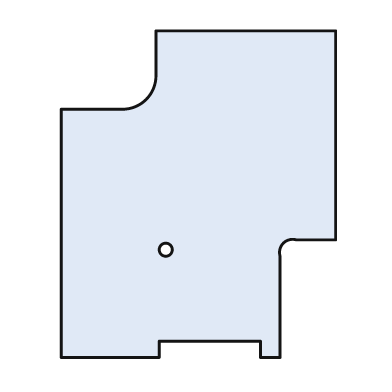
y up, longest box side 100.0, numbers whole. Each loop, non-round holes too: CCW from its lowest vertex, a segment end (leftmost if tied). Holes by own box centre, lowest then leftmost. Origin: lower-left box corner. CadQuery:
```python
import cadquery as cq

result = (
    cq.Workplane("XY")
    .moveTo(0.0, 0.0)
    .lineTo(30.0, 0.0)
    .lineTo(30.0, 5.0)
    .lineTo(61.0, 5.0)
    .lineTo(61.0, 0.0)
    .lineTo(67.0, 0.0)
    .lineTo(67.0, 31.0)
    .threePointArc((68.0, 35.0), (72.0, 36.0))
    .lineTo(84.0, 36.0)
    .lineTo(84.0, 100.0)
    .lineTo(29.0, 100.0)
    .lineTo(29.0, 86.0)
    .threePointArc((26.0, 79.0), (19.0, 76.0))
    .lineTo(0.0, 76.0)
    .close()
    .moveTo(32.0, 33.0)
    .circle(2.0)
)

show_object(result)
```